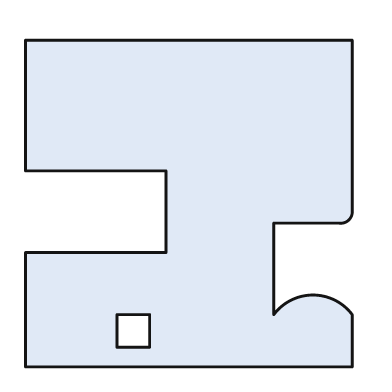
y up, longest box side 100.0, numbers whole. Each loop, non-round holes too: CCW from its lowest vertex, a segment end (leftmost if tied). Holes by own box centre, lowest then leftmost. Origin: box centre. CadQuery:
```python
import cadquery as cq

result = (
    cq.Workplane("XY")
    .moveTo(-50.0, -50.0)
    .lineTo(50.0, -50.0)
    .lineTo(50.0, -34.0)
    .threePointArc((38.0, -28.0), (26.0, -34.0))
    .lineTo(26.0, -6.0)
    .lineTo(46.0, -6.0)
    .threePointArc((49.0, -5.0), (50.0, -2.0))
    .lineTo(50.0, 50.0)
    .lineTo(-50.0, 50.0)
    .lineTo(-50.0, 10.0)
    .lineTo(-7.0, 10.0)
    .lineTo(-7.0, -15.0)
    .lineTo(-50.0, -15.0)
    .close()
    .moveTo(-22.0, -44.0)
    .lineTo(-12.0, -44.0)
    .lineTo(-12.0, -34.0)
    .lineTo(-22.0, -34.0)
    .close()
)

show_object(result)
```